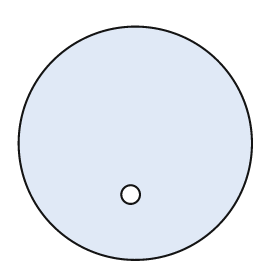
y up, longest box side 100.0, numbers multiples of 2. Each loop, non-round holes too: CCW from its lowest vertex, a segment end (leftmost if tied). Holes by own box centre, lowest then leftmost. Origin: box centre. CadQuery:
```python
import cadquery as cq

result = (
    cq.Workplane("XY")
    .moveTo(0.0, 0.0)
    .circle(50.0)
    .moveTo(-2.0, -22.0)
    .circle(4.0)
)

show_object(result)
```